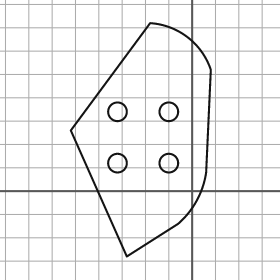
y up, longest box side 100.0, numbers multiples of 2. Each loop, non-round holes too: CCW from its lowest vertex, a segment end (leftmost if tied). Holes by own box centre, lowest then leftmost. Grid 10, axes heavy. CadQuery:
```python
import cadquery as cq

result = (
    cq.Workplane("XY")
    .moveTo(-28.0, -28.0)
    .lineTo(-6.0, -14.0)
    .threePointArc((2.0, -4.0), (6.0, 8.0))
    .lineTo(8.0, 52.0)
    .threePointArc((-2.0, 66.0), (-18.0, 72.0))
    .lineTo(-52.0, 26.0)
    .close()
    .moveTo(-32.0, 12.0)
    .circle(4.0)
    .moveTo(-10.0, 12.0)
    .circle(4.0)
    .moveTo(-32.0, 34.0)
    .circle(4.0)
    .moveTo(-10.0, 34.0)
    .circle(4.0)
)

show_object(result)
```